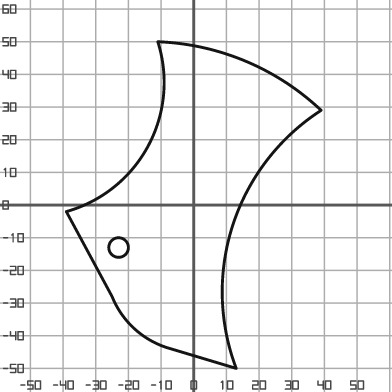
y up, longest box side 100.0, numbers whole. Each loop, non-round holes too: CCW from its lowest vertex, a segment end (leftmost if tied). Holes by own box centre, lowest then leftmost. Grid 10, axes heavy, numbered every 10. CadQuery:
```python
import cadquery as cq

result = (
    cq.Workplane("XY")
    .moveTo(13.0, -50.0)
    .threePointArc((12.0, -6.0), (39.0, 29.0))
    .threePointArc((16.0, 44.0), (-11.0, 50.0))
    .threePointArc((-14.0, 18.0), (-39.0, -2.0))
    .lineTo(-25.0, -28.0)
    .threePointArc((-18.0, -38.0), (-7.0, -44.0))
    .close()
    .moveTo(-23.0, -13.0)
    .circle(3.0)
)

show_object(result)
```